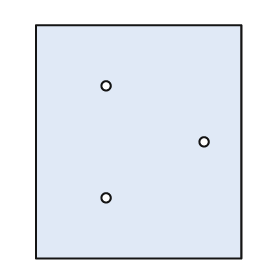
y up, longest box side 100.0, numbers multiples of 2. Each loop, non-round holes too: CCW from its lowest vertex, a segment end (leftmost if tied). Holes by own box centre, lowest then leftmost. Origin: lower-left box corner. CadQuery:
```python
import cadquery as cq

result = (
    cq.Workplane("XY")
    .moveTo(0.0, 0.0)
    .lineTo(88.0, 0.0)
    .lineTo(88.0, 100.0)
    .lineTo(0.0, 100.0)
    .close()
    .moveTo(30.0, 26.0)
    .circle(2.0)
    .moveTo(72.0, 50.0)
    .circle(2.0)
    .moveTo(30.0, 74.0)
    .circle(2.0)
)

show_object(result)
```